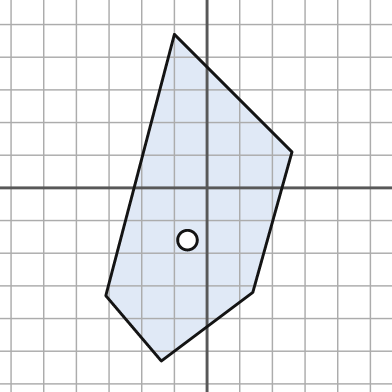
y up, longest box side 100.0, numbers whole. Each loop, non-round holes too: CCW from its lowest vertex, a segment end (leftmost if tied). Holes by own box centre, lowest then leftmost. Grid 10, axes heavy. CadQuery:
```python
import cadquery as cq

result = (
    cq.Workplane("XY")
    .moveTo(-14.0, -53.0)
    .lineTo(14.0, -32.0)
    .lineTo(26.0, 11.0)
    .lineTo(-10.0, 47.0)
    .lineTo(-31.0, -33.0)
    .close()
    .moveTo(-6.0, -16.0)
    .circle(3.0)
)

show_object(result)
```